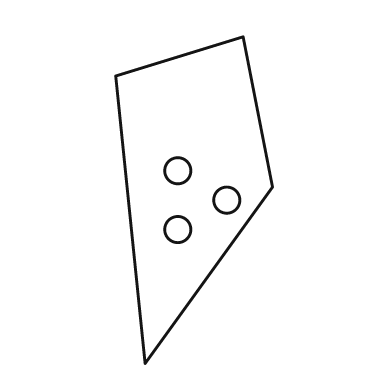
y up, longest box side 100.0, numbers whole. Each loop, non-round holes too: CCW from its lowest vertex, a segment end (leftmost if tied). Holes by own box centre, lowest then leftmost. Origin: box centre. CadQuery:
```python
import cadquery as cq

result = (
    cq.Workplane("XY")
    .moveTo(-15.0, -50.0)
    .lineTo(24.0, 4.0)
    .lineTo(15.0, 50.0)
    .lineTo(-24.0, 38.0)
    .close()
    .moveTo(-5.0, -9.0)
    .circle(4.0)
    .moveTo(10.0, 0.0)
    .circle(4.0)
    .moveTo(-5.0, 9.0)
    .circle(4.0)
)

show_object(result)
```